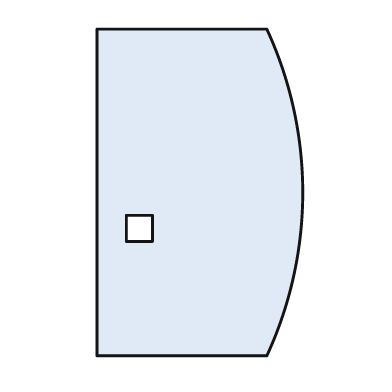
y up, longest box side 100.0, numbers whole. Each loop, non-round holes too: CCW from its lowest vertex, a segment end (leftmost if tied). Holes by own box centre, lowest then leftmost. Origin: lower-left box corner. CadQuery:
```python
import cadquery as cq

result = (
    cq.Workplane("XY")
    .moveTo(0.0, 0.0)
    .lineTo(52.0, 0.0)
    .threePointArc((63.0, 50.0), (52.0, 100.0))
    .lineTo(0.0, 100.0)
    .close()
    .moveTo(9.0, 35.0)
    .lineTo(17.0, 35.0)
    .lineTo(17.0, 43.0)
    .lineTo(9.0, 43.0)
    .close()
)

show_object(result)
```